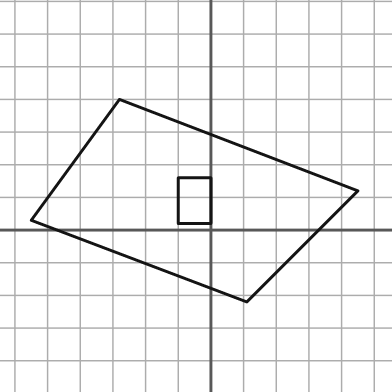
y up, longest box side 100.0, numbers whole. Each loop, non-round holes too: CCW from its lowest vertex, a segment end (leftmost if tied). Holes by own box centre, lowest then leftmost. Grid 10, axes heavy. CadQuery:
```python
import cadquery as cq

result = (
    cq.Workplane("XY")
    .moveTo(11.0, -22.0)
    .lineTo(45.0, 12.0)
    .lineTo(-28.0, 40.0)
    .lineTo(-55.0, 3.0)
    .close()
    .moveTo(-10.0, 2.0)
    .lineTo(0.0, 2.0)
    .lineTo(0.0, 16.0)
    .lineTo(-10.0, 16.0)
    .close()
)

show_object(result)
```